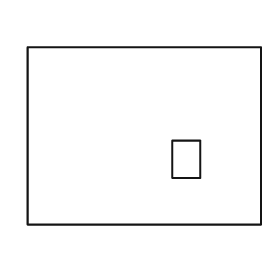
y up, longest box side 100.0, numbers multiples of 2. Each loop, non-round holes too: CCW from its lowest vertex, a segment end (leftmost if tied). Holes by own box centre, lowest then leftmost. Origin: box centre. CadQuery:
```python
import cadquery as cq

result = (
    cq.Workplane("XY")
    .moveTo(-50.0, -38.0)
    .lineTo(50.0, -38.0)
    .lineTo(50.0, 38.0)
    .lineTo(-50.0, 38.0)
    .close()
    .moveTo(12.0, -18.0)
    .lineTo(24.0, -18.0)
    .lineTo(24.0, -2.0)
    .lineTo(12.0, -2.0)
    .close()
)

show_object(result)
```